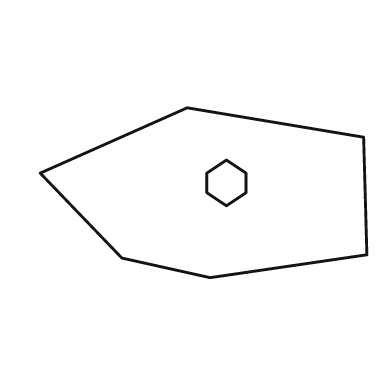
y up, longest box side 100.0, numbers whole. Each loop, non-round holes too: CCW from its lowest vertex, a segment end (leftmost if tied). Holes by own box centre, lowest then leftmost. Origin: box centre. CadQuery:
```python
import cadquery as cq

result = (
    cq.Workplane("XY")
    .moveTo(2.0, -26.0)
    .lineTo(50.0, -19.0)
    .lineTo(49.0, 17.0)
    .lineTo(-5.0, 26.0)
    .lineTo(-50.0, 6.0)
    .lineTo(-25.0, -20.0)
    .close()
    .moveTo(7.0, -4.0)
    .lineTo(13.0, 0.0)
    .lineTo(13.0, 6.0)
    .lineTo(7.0, 10.0)
    .lineTo(1.0, 6.0)
    .lineTo(1.0, 0.0)
    .close()
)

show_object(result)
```